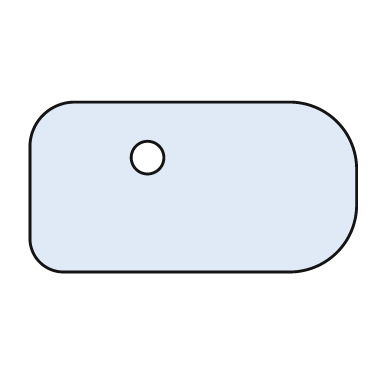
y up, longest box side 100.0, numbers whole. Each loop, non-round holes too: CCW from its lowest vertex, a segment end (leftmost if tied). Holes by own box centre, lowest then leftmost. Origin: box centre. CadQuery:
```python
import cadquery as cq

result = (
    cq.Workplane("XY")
    .moveTo(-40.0, -26.0)
    .lineTo(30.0, -26.0)
    .threePointArc((44.0, -20.0), (50.0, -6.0))
    .lineTo(50.0, 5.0)
    .threePointArc((44.0, 20.0), (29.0, 26.0))
    .lineTo(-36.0, 26.0)
    .threePointArc((-46.0, 22.0), (-50.0, 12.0))
    .lineTo(-50.0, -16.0)
    .threePointArc((-47.0, -23.0), (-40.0, -26.0))
    .close()
    .moveTo(-14.0, 9.0)
    .circle(5.0)
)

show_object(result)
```